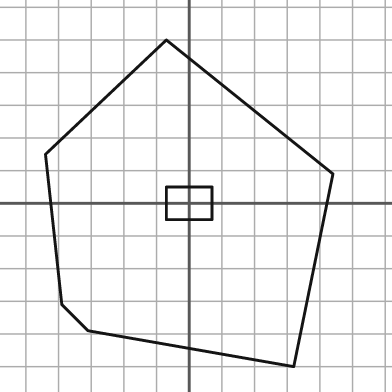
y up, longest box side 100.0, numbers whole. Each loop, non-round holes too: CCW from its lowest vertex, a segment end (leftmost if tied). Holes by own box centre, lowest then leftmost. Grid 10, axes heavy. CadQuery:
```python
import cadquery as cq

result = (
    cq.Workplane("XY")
    .moveTo(32.0, -50.0)
    .lineTo(44.0, 9.0)
    .lineTo(-7.0, 50.0)
    .lineTo(-44.0, 15.0)
    .lineTo(-39.0, -31.0)
    .lineTo(-31.0, -39.0)
    .close()
    .moveTo(-7.0, -5.0)
    .lineTo(7.0, -5.0)
    .lineTo(7.0, 5.0)
    .lineTo(-7.0, 5.0)
    .close()
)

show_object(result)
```